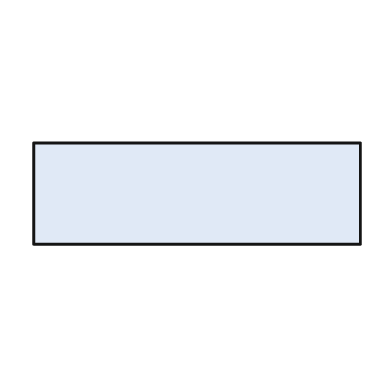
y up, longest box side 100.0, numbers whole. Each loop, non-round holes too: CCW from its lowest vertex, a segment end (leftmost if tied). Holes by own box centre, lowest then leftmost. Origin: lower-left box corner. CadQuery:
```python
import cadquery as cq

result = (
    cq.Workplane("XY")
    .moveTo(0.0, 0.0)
    .lineTo(100.0, 0.0)
    .lineTo(100.0, 31.0)
    .lineTo(0.0, 31.0)
    .close()
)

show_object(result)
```